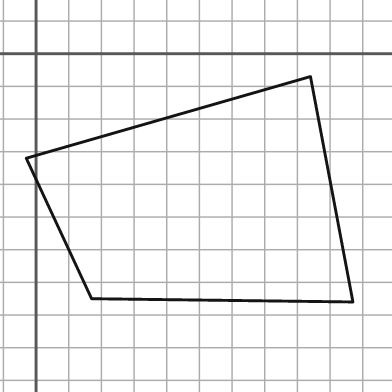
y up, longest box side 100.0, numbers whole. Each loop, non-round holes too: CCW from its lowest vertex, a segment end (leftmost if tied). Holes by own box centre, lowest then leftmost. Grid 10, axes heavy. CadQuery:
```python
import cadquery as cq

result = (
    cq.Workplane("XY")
    .moveTo(97.0, -76.0)
    .lineTo(84.0, -7.0)
    .lineTo(-3.0, -32.0)
    .lineTo(17.0, -75.0)
    .close()
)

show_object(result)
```